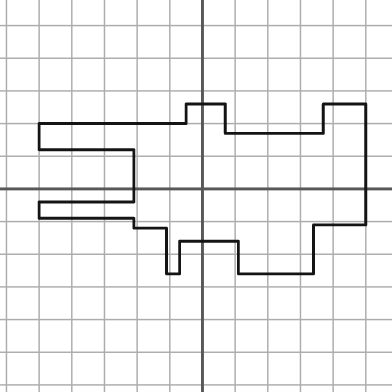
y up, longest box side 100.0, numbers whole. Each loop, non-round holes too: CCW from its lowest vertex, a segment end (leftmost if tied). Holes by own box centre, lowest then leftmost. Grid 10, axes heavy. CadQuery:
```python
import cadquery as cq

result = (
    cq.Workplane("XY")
    .moveTo(-11.0, -26.0)
    .lineTo(-7.0, -26.0)
    .lineTo(-7.0, -16.0)
    .lineTo(11.0, -16.0)
    .lineTo(11.0, -26.0)
    .lineTo(34.0, -26.0)
    .lineTo(34.0, -11.0)
    .lineTo(50.0, -11.0)
    .lineTo(50.0, 26.0)
    .lineTo(37.0, 26.0)
    .lineTo(37.0, 17.0)
    .lineTo(7.0, 17.0)
    .lineTo(7.0, 26.0)
    .lineTo(-5.0, 26.0)
    .lineTo(-5.0, 20.0)
    .lineTo(-50.0, 20.0)
    .lineTo(-50.0, 12.0)
    .lineTo(-21.0, 12.0)
    .lineTo(-21.0, -4.0)
    .lineTo(-50.0, -4.0)
    .lineTo(-50.0, -9.0)
    .lineTo(-21.0, -9.0)
    .lineTo(-21.0, -12.0)
    .lineTo(-11.0, -12.0)
    .close()
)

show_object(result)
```